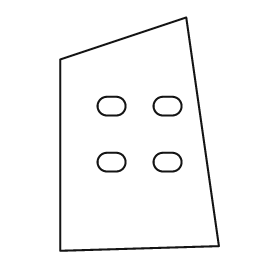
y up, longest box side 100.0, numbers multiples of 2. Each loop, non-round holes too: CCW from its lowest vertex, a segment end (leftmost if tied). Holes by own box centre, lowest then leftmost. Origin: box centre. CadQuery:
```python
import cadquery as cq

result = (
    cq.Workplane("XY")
    .moveTo(-34.0, -50.0)
    .lineTo(34.0, -48.0)
    .lineTo(20.0, 50.0)
    .lineTo(-34.0, 32.0)
    .close()
    .moveTo(-14.0, -16.0)
    .lineTo(-10.0, -16.0)
    .threePointArc((-6.0, -12.0), (-10.0, -8.0))
    .lineTo(-14.0, -8.0)
    .threePointArc((-18.0, -12.0), (-14.0, -16.0))
    .close()
    .moveTo(10.0, -16.0)
    .lineTo(14.0, -16.0)
    .threePointArc((18.0, -12.0), (14.0, -8.0))
    .lineTo(10.0, -8.0)
    .threePointArc((6.0, -12.0), (10.0, -16.0))
    .close()
    .moveTo(-14.0, 8.0)
    .lineTo(-10.0, 8.0)
    .threePointArc((-6.0, 12.0), (-10.0, 16.0))
    .lineTo(-14.0, 16.0)
    .threePointArc((-18.0, 12.0), (-14.0, 8.0))
    .close()
    .moveTo(10.0, 8.0)
    .lineTo(14.0, 8.0)
    .threePointArc((18.0, 12.0), (14.0, 16.0))
    .lineTo(10.0, 16.0)
    .threePointArc((6.0, 12.0), (10.0, 8.0))
    .close()
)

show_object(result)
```